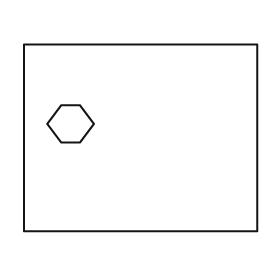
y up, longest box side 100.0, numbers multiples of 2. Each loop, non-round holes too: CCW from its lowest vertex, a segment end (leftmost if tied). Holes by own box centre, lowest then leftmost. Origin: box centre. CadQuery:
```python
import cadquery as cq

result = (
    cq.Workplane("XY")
    .moveTo(-50.0, -40.0)
    .lineTo(50.0, -40.0)
    .lineTo(50.0, 40.0)
    .lineTo(-50.0, 40.0)
    .close()
    .moveTo(-34.0, -2.0)
    .lineTo(-26.0, -2.0)
    .lineTo(-20.0, 6.0)
    .lineTo(-26.0, 14.0)
    .lineTo(-34.0, 14.0)
    .lineTo(-40.0, 6.0)
    .close()
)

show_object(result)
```